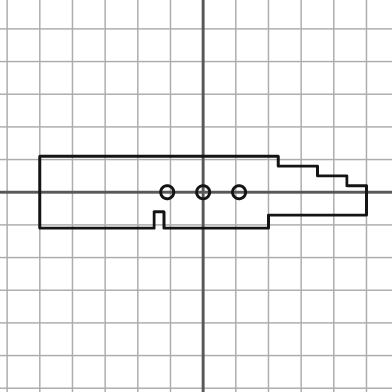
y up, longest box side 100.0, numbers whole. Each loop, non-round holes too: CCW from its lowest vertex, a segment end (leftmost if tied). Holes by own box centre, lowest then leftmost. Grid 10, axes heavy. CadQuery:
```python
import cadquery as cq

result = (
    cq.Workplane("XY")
    .moveTo(-50.0, -11.0)
    .lineTo(-15.0, -11.0)
    .lineTo(-15.0, -6.0)
    .lineTo(-12.0, -6.0)
    .lineTo(-12.0, -11.0)
    .lineTo(20.0, -11.0)
    .lineTo(20.0, -7.0)
    .lineTo(50.0, -7.0)
    .lineTo(50.0, 2.0)
    .lineTo(44.0, 2.0)
    .lineTo(44.0, 5.0)
    .lineTo(35.0, 5.0)
    .lineTo(35.0, 8.0)
    .lineTo(23.0, 8.0)
    .lineTo(23.0, 11.0)
    .lineTo(-50.0, 11.0)
    .close()
    .moveTo(-11.0, 0.0)
    .circle(2.0)
    .moveTo(0.0, 0.0)
    .circle(2.0)
    .moveTo(11.0, 0.0)
    .circle(2.0)
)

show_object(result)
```